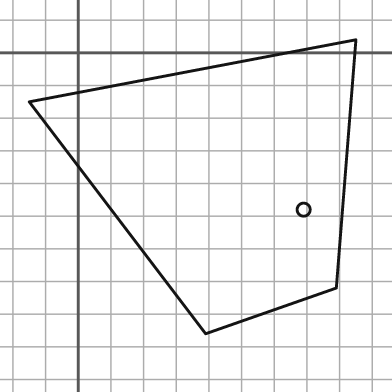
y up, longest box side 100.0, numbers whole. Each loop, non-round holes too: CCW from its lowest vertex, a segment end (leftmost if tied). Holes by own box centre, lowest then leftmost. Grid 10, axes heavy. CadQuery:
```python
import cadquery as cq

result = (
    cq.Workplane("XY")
    .moveTo(39.0, -86.0)
    .lineTo(79.0, -72.0)
    .lineTo(85.0, 4.0)
    .lineTo(-15.0, -15.0)
    .close()
    .moveTo(69.0, -48.0)
    .circle(2.0)
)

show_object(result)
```